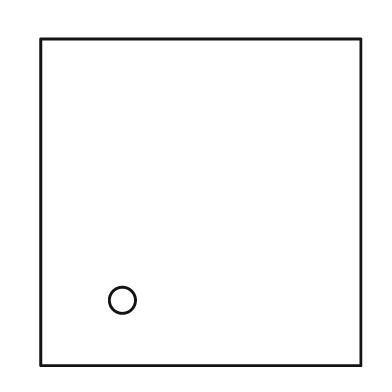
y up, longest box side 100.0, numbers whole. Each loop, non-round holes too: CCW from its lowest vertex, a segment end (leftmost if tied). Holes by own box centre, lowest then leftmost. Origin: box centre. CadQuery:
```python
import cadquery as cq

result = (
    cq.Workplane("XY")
    .moveTo(-49.0, -50.0)
    .lineTo(49.0, -50.0)
    .lineTo(49.0, 50.0)
    .lineTo(-49.0, 50.0)
    .close()
    .moveTo(-24.0, -30.0)
    .circle(4.0)
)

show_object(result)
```